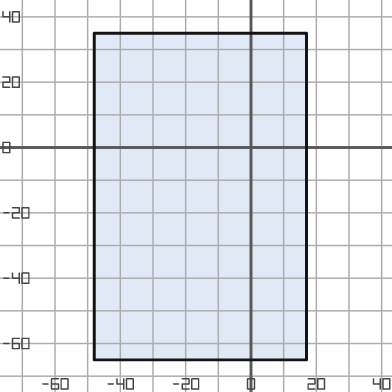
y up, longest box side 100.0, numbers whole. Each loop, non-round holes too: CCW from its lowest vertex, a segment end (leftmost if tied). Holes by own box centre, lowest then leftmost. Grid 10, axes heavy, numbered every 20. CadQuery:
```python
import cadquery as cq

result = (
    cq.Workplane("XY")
    .moveTo(-48.0, -65.0)
    .lineTo(17.0, -65.0)
    .lineTo(17.0, 35.0)
    .lineTo(-48.0, 35.0)
    .close()
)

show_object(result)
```